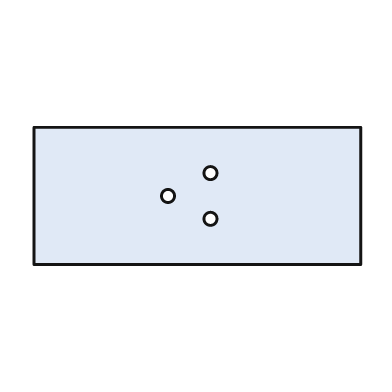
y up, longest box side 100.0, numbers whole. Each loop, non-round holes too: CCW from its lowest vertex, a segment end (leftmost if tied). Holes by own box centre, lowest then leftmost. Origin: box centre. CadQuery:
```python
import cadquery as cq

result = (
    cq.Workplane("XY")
    .moveTo(-50.0, -21.0)
    .lineTo(50.0, -21.0)
    .lineTo(50.0, 21.0)
    .lineTo(-50.0, 21.0)
    .close()
    .moveTo(4.0, -7.0)
    .circle(2.0)
    .moveTo(-9.0, 0.0)
    .circle(2.0)
    .moveTo(4.0, 7.0)
    .circle(2.0)
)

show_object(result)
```